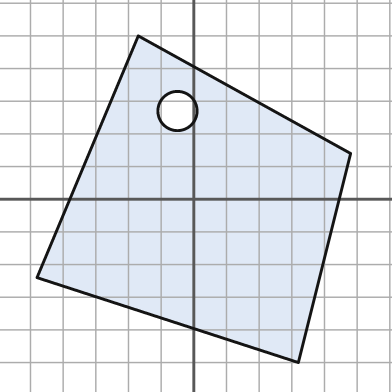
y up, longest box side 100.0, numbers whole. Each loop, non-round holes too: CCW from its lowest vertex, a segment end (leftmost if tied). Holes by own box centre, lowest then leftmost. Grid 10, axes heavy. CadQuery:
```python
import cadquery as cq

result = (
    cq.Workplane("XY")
    .moveTo(32.0, -50.0)
    .lineTo(48.0, 14.0)
    .lineTo(-17.0, 50.0)
    .lineTo(-48.0, -24.0)
    .close()
    .moveTo(-5.0, 27.0)
    .circle(6.0)
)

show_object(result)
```